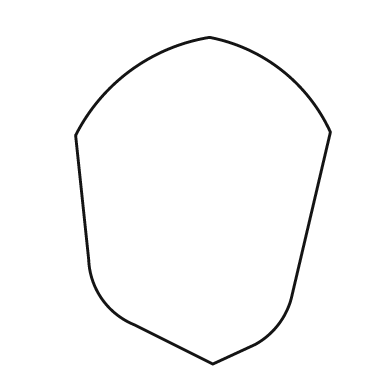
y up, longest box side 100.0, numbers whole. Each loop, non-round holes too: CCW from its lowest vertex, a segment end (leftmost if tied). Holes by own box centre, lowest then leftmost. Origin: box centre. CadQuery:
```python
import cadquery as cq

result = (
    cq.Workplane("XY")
    .moveTo(3.0, -50.0)
    .lineTo(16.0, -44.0)
    .threePointArc((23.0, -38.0), (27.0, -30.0))
    .lineTo(39.0, 21.0)
    .threePointArc((24.0, 40.0), (2.0, 50.0))
    .threePointArc((-22.0, 40.0), (-39.0, 20.0))
    .lineTo(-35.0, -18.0)
    .threePointArc((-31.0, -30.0), (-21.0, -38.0))
    .close()
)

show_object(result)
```